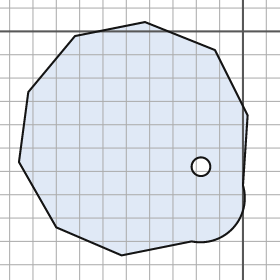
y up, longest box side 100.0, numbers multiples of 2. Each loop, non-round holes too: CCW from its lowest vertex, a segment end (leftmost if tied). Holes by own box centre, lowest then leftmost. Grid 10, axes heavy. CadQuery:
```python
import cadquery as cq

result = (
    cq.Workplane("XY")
    .moveTo(-52.0, -96.0)
    .lineTo(-22.0, -90.0)
    .threePointArc((-4.0, -84.0), (0.0, -66.0))
    .lineTo(2.0, -36.0)
    .lineTo(-12.0, -8.0)
    .lineTo(-42.0, 4.0)
    .lineTo(-72.0, -2.0)
    .lineTo(-92.0, -26.0)
    .lineTo(-96.0, -56.0)
    .lineTo(-80.0, -84.0)
    .close()
    .moveTo(-18.0, -58.0)
    .circle(4.0)
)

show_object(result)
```